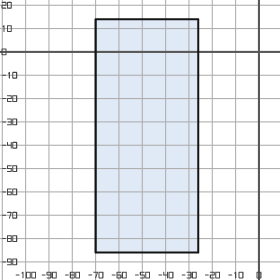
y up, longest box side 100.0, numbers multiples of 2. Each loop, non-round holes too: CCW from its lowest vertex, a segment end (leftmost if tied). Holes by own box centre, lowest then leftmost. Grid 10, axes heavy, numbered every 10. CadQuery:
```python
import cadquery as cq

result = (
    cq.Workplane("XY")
    .moveTo(-70.0, -86.0)
    .lineTo(-26.0, -86.0)
    .lineTo(-26.0, 14.0)
    .lineTo(-70.0, 14.0)
    .close()
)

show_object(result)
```